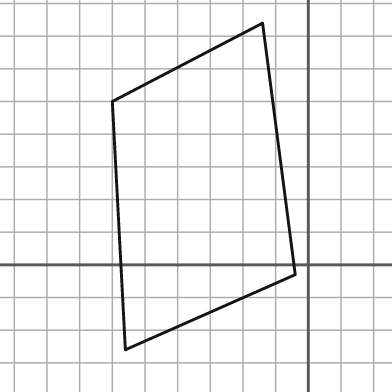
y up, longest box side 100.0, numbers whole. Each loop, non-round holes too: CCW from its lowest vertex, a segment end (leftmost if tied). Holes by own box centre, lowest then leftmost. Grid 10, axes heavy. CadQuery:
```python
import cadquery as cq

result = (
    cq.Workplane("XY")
    .moveTo(-56.0, -26.0)
    .lineTo(-4.0, -3.0)
    .lineTo(-14.0, 74.0)
    .lineTo(-60.0, 50.0)
    .close()
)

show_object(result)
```